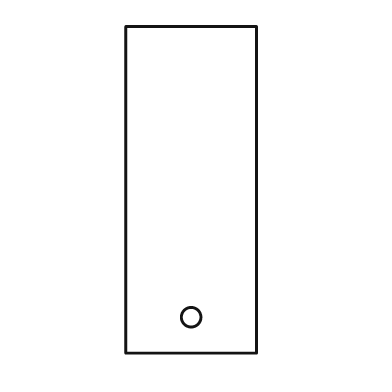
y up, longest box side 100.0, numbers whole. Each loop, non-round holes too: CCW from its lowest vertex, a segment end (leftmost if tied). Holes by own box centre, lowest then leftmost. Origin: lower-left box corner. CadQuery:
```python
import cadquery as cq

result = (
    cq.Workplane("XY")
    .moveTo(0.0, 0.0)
    .lineTo(40.0, 0.0)
    .lineTo(40.0, 100.0)
    .lineTo(0.0, 100.0)
    .close()
    .moveTo(20.0, 11.0)
    .circle(3.0)
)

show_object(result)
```